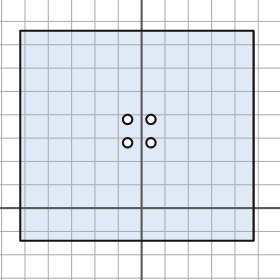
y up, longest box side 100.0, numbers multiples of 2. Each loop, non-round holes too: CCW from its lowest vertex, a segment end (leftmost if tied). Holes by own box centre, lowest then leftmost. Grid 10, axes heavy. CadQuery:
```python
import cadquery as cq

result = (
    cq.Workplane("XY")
    .moveTo(-52.0, -14.0)
    .lineTo(48.0, -14.0)
    .lineTo(48.0, 76.0)
    .lineTo(-52.0, 76.0)
    .close()
    .moveTo(-6.0, 28.0)
    .circle(2.0)
    .moveTo(4.0, 28.0)
    .circle(2.0)
    .moveTo(-6.0, 38.0)
    .circle(2.0)
    .moveTo(4.0, 38.0)
    .circle(2.0)
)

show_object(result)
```